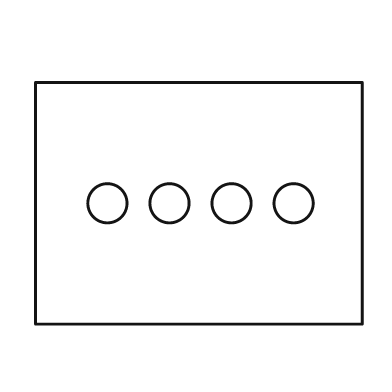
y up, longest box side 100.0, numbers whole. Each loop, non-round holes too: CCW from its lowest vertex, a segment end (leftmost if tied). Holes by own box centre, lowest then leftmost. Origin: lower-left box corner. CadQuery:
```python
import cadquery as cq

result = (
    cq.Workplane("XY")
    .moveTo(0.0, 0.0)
    .lineTo(100.0, 0.0)
    .lineTo(100.0, 74.0)
    .lineTo(0.0, 74.0)
    .close()
    .moveTo(22.0, 37.0)
    .circle(6.0)
    .moveTo(41.0, 37.0)
    .circle(6.0)
    .moveTo(60.0, 37.0)
    .circle(6.0)
    .moveTo(79.0, 37.0)
    .circle(6.0)
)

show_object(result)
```